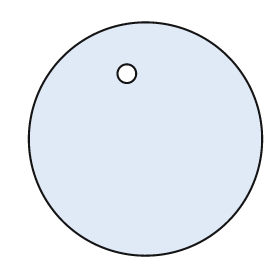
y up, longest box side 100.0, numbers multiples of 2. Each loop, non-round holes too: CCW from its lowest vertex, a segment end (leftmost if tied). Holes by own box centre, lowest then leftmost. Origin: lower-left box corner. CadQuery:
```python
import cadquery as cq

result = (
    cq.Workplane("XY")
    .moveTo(50.0, 50.0)
    .circle(50.0)
    .moveTo(42.0, 78.0)
    .circle(4.0)
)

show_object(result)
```